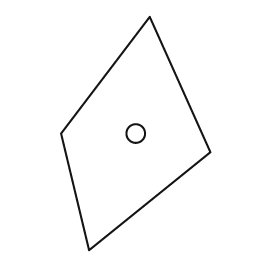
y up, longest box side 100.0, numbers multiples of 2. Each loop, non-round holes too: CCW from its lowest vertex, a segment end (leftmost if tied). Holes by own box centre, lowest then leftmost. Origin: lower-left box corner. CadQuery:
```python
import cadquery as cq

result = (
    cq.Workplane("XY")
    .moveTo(12.0, 0.0)
    .lineTo(64.0, 42.0)
    .lineTo(38.0, 100.0)
    .lineTo(0.0, 50.0)
    .close()
    .moveTo(32.0, 50.0)
    .circle(4.0)
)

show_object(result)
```